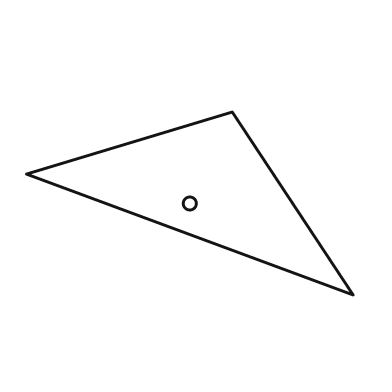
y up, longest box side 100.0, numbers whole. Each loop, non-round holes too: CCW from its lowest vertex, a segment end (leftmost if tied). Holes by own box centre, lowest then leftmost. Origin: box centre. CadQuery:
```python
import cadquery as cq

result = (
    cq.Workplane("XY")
    .moveTo(50.0, -28.0)
    .lineTo(13.0, 28.0)
    .lineTo(-50.0, 9.0)
    .close()
    .moveTo(0.0, 0.0)
    .circle(2.0)
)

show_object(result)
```